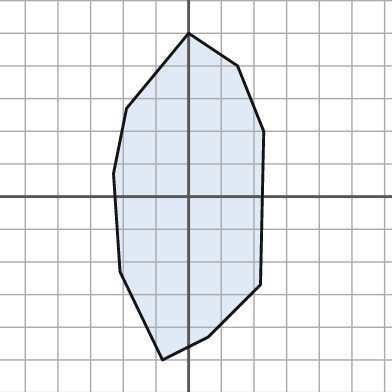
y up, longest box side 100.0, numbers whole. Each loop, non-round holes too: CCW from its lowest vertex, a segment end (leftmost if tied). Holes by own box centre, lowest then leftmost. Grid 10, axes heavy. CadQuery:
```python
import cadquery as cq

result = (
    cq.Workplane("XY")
    .moveTo(-8.0, -50.0)
    .lineTo(6.0, -43.0)
    .lineTo(22.0, -27.0)
    .lineTo(23.0, 20.0)
    .lineTo(15.0, 40.0)
    .lineTo(0.0, 50.0)
    .lineTo(-19.0, 27.0)
    .lineTo(-23.0, 7.0)
    .lineTo(-21.0, -23.0)
    .close()
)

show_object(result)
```